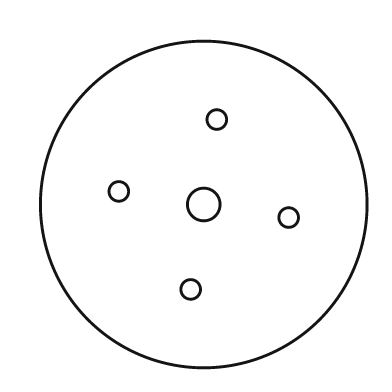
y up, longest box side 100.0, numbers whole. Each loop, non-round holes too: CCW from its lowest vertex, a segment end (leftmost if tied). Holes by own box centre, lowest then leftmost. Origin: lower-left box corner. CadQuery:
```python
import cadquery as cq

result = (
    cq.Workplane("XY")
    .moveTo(50.0, 50.0)
    .circle(50.0)
    .moveTo(46.0, 24.0)
    .circle(3.0)
    .moveTo(76.0, 46.0)
    .circle(3.0)
    .moveTo(50.0, 50.0)
    .circle(5.0)
    .moveTo(24.0, 54.0)
    .circle(3.0)
    .moveTo(54.0, 76.0)
    .circle(3.0)
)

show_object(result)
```